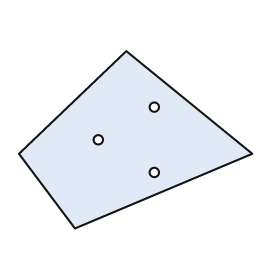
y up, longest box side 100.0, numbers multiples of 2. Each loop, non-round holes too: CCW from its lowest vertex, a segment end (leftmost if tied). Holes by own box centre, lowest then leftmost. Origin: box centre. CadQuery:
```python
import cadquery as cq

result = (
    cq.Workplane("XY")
    .moveTo(-26.0, -38.0)
    .lineTo(50.0, -6.0)
    .lineTo(-4.0, 38.0)
    .lineTo(-50.0, -6.0)
    .close()
    .moveTo(8.0, -14.0)
    .circle(2.0)
    .moveTo(-16.0, 0.0)
    .circle(2.0)
    .moveTo(8.0, 14.0)
    .circle(2.0)
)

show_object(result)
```